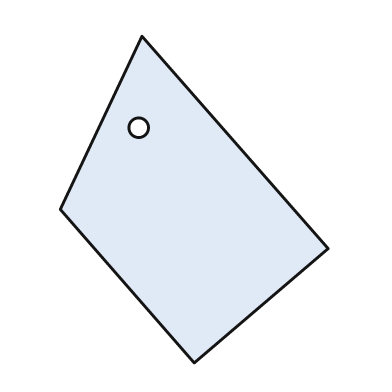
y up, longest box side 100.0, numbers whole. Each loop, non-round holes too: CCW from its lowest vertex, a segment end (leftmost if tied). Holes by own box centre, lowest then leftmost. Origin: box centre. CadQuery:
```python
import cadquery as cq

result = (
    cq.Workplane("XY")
    .moveTo(0.0, -50.0)
    .lineTo(41.0, -15.0)
    .lineTo(-16.0, 50.0)
    .lineTo(-41.0, -3.0)
    .close()
    .moveTo(-17.0, 22.0)
    .circle(3.0)
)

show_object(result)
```